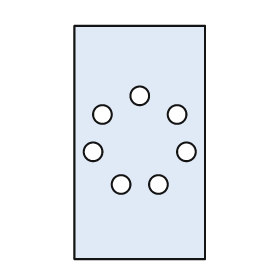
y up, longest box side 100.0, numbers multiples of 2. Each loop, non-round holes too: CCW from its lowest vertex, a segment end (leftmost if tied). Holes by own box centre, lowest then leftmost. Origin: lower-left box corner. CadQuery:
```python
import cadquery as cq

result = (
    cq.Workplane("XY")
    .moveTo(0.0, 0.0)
    .lineTo(56.0, 0.0)
    .lineTo(56.0, 100.0)
    .lineTo(0.0, 100.0)
    .close()
    .moveTo(20.0, 32.0)
    .circle(4.0)
    .moveTo(36.0, 32.0)
    .circle(4.0)
    .moveTo(8.0, 46.0)
    .circle(4.0)
    .moveTo(48.0, 46.0)
    .circle(4.0)
    .moveTo(12.0, 62.0)
    .circle(4.0)
    .moveTo(44.0, 62.0)
    .circle(4.0)
    .moveTo(28.0, 70.0)
    .circle(4.0)
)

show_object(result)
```